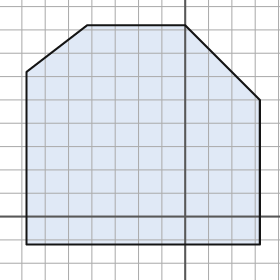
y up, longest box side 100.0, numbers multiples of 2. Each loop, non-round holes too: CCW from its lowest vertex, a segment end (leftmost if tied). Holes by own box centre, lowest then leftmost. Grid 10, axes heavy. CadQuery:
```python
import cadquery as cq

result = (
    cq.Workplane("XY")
    .moveTo(-68.0, -12.0)
    .lineTo(32.0, -12.0)
    .lineTo(32.0, 50.0)
    .lineTo(0.0, 82.0)
    .lineTo(-42.0, 82.0)
    .lineTo(-68.0, 62.0)
    .close()
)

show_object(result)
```